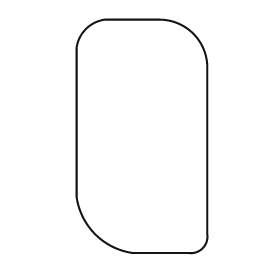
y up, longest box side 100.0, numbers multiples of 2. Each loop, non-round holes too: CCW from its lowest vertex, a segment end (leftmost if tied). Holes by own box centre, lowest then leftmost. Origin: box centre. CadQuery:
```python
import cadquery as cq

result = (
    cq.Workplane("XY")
    .moveTo(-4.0, -50.0)
    .lineTo(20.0, -50.0)
    .threePointArc((26.0, -48.0), (28.0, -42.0))
    .lineTo(28.0, 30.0)
    .threePointArc((22.0, 44.0), (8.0, 50.0))
    .lineTo(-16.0, 50.0)
    .threePointArc((-24.0, 46.0), (-28.0, 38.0))
    .lineTo(-28.0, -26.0)
    .threePointArc((-20.0, -42.0), (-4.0, -50.0))
    .close()
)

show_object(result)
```